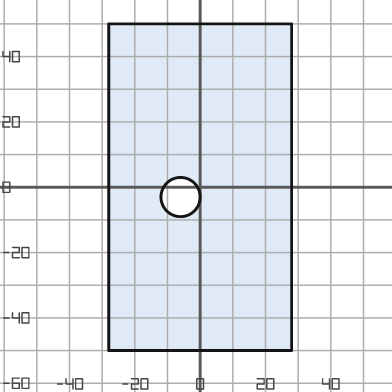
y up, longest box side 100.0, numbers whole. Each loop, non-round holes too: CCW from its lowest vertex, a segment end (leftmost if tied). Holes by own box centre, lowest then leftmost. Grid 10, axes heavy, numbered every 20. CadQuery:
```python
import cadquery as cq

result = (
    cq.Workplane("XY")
    .moveTo(-28.0, -50.0)
    .lineTo(28.0, -50.0)
    .lineTo(28.0, 50.0)
    .lineTo(-28.0, 50.0)
    .close()
    .moveTo(-6.0, -3.0)
    .circle(6.0)
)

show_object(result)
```